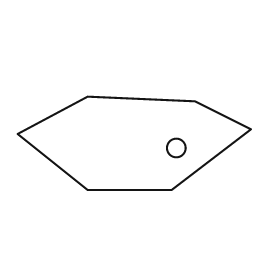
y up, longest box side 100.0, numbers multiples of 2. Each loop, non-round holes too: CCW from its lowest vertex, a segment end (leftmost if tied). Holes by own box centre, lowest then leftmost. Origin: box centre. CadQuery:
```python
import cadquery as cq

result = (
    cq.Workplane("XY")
    .moveTo(-20.0, -20.0)
    .lineTo(16.0, -20.0)
    .lineTo(50.0, 6.0)
    .lineTo(26.0, 18.0)
    .lineTo(-20.0, 20.0)
    .lineTo(-50.0, 4.0)
    .close()
    .moveTo(18.0, -2.0)
    .circle(4.0)
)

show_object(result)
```